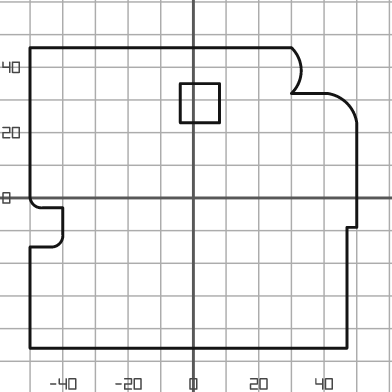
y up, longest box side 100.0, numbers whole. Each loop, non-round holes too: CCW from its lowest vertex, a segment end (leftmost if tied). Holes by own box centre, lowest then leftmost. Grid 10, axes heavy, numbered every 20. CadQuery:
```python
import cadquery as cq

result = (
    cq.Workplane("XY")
    .moveTo(-50.0, -46.0)
    .lineTo(47.0, -46.0)
    .lineTo(47.0, -9.0)
    .lineTo(50.0, -9.0)
    .lineTo(50.0, 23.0)
    .threePointArc((47.0, 29.0), (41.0, 32.0))
    .lineTo(30.0, 32.0)
    .threePointArc((33.0, 39.0), (30.0, 46.0))
    .lineTo(-50.0, 46.0)
    .lineTo(-50.0, 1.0)
    .threePointArc((-49.0, -2.0), (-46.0, -3.0))
    .lineTo(-40.0, -3.0)
    .lineTo(-40.0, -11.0)
    .threePointArc((-41.0, -14.0), (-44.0, -15.0))
    .lineTo(-50.0, -15.0)
    .close()
    .moveTo(-4.0, 23.0)
    .lineTo(8.0, 23.0)
    .lineTo(8.0, 35.0)
    .lineTo(-4.0, 35.0)
    .close()
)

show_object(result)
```